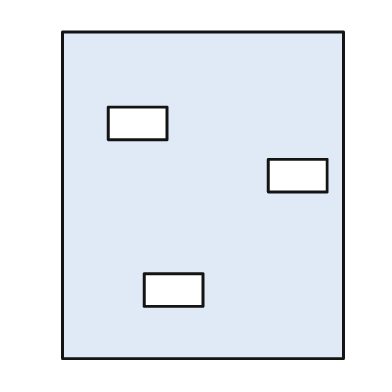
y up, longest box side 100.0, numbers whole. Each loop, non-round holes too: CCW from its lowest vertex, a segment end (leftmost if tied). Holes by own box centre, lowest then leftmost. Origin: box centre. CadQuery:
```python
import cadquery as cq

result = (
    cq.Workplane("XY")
    .moveTo(-43.0, -50.0)
    .lineTo(43.0, -50.0)
    .lineTo(43.0, 50.0)
    .lineTo(-43.0, 50.0)
    .close()
    .moveTo(-18.0, -34.0)
    .lineTo(0.0, -34.0)
    .lineTo(0.0, -24.0)
    .lineTo(-18.0, -24.0)
    .close()
    .moveTo(20.0, 1.0)
    .lineTo(38.0, 1.0)
    .lineTo(38.0, 11.0)
    .lineTo(20.0, 11.0)
    .close()
    .moveTo(-29.0, 17.0)
    .lineTo(-11.0, 17.0)
    .lineTo(-11.0, 27.0)
    .lineTo(-29.0, 27.0)
    .close()
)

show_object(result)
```